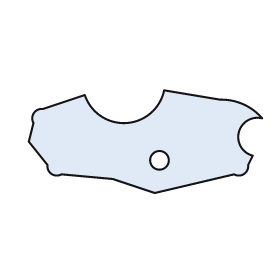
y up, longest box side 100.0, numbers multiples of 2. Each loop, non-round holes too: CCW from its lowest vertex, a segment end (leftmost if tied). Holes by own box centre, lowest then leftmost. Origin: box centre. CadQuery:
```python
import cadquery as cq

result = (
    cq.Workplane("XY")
    .moveTo(4.0, -22.0)
    .lineTo(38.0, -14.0)
    .threePointArc((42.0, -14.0), (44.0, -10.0))
    .lineTo(46.0, -6.0)
    .threePointArc((40.0, 4.0), (50.0, 10.0))
    .threePointArc((42.0, 16.0), (32.0, 18.0))
    .lineTo(8.0, 22.0)
    .threePointArc((-8.0, 8.0), (-26.0, 20.0))
    .lineTo(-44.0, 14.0)
    .threePointArc((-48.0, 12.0), (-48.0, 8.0))
    .lineTo(-50.0, 0.0)
    .lineTo(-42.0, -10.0)
    .threePointArc((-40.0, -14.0), (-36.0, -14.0))
    .lineTo(-14.0, -16.0)
    .close()
    .moveTo(6.0, -8.0)
    .circle(4.0)
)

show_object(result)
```